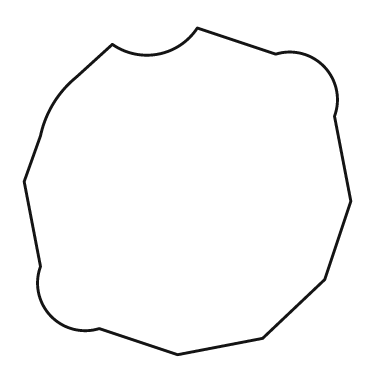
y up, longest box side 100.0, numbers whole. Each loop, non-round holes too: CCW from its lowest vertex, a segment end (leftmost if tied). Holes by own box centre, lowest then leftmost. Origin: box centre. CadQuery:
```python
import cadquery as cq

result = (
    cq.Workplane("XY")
    .moveTo(-3.0, -50.0)
    .lineTo(23.0, -45.0)
    .lineTo(42.0, -27.0)
    .lineTo(50.0, -3.0)
    .lineTo(45.0, 23.0)
    .threePointArc((42.0, 38.0), (27.0, 42.0))
    .lineTo(3.0, 50.0)
    .threePointArc((-9.0, 42.0), (-23.0, 45.0))
    .lineTo(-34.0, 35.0)
    .threePointArc((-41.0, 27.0), (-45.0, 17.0))
    .lineTo(-50.0, 3.0)
    .lineTo(-45.0, -23.0)
    .threePointArc((-42.0, -38.0), (-27.0, -42.0))
    .close()
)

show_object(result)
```